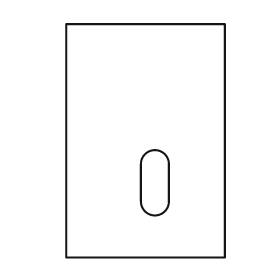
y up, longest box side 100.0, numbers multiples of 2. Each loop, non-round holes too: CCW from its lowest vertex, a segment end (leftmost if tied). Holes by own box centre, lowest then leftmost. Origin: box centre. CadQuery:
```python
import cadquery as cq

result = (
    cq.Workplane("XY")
    .moveTo(-34.0, -50.0)
    .lineTo(34.0, -50.0)
    .lineTo(34.0, 50.0)
    .lineTo(-34.0, 50.0)
    .close()
    .moveTo(-2.0, -26.0)
    .threePointArc((4.0, -32.0), (10.0, -26.0))
    .lineTo(10.0, -10.0)
    .threePointArc((4.0, -4.0), (-2.0, -10.0))
    .close()
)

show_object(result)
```